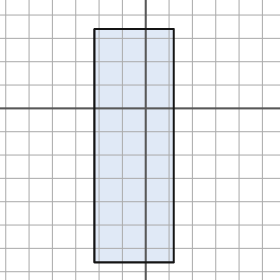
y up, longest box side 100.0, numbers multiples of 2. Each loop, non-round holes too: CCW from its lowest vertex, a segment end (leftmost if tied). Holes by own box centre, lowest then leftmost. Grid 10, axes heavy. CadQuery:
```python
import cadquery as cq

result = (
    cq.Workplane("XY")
    .moveTo(-22.0, -66.0)
    .lineTo(12.0, -66.0)
    .lineTo(12.0, 34.0)
    .lineTo(-22.0, 34.0)
    .close()
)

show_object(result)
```